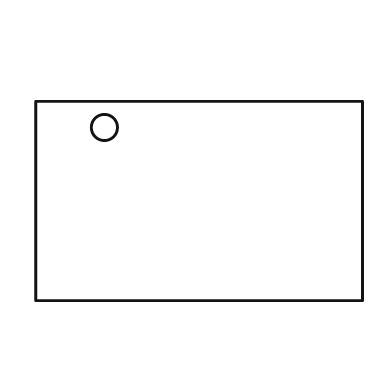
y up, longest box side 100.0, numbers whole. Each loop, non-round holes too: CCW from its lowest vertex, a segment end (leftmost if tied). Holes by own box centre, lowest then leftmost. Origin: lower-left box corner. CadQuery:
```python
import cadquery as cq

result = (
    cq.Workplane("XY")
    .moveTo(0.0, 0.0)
    .lineTo(100.0, 0.0)
    .lineTo(100.0, 61.0)
    .lineTo(0.0, 61.0)
    .close()
    .moveTo(21.0, 53.0)
    .circle(4.0)
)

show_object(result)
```